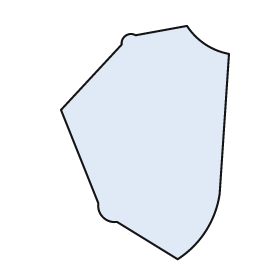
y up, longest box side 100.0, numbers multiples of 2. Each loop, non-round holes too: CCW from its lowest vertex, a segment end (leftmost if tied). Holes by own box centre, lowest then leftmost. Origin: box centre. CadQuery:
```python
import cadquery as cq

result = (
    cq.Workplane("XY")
    .moveTo(14.0, -50.0)
    .threePointArc((26.0, -38.0), (32.0, -22.0))
    .lineTo(36.0, 38.0)
    .threePointArc((26.0, 42.0), (18.0, 50.0))
    .lineTo(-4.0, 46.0)
    .threePointArc((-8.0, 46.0), (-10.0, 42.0))
    .lineTo(-36.0, 14.0)
    .lineTo(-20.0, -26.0)
    .threePointArc((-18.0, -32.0), (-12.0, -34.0))
    .close()
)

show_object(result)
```